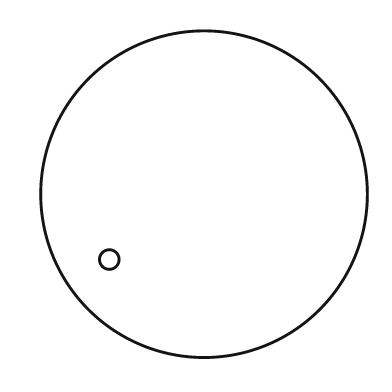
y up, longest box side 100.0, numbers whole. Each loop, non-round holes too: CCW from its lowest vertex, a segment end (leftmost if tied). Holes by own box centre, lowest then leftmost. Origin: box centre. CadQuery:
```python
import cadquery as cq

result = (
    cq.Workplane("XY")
    .moveTo(0.0, 0.0)
    .circle(50.0)
    .moveTo(-29.0, -20.0)
    .circle(3.0)
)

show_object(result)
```